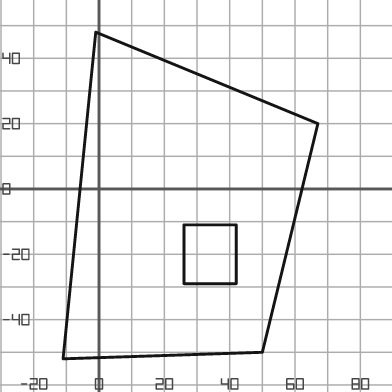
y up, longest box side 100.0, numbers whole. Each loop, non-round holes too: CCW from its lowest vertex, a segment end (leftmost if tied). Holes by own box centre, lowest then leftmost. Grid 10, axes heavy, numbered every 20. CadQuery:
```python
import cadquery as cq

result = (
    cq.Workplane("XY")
    .moveTo(-11.0, -52.0)
    .lineTo(50.0, -50.0)
    .lineTo(67.0, 20.0)
    .lineTo(-1.0, 48.0)
    .close()
    .moveTo(26.0, -29.0)
    .lineTo(42.0, -29.0)
    .lineTo(42.0, -11.0)
    .lineTo(26.0, -11.0)
    .close()
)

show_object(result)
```